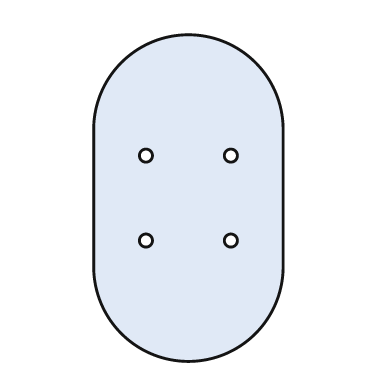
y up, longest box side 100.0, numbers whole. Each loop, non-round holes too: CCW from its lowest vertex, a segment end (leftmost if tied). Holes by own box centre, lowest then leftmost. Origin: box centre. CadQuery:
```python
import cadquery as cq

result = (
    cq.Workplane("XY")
    .moveTo(-29.0, -21.0)
    .threePointArc((0.0, -50.0), (29.0, -21.0))
    .lineTo(29.0, 21.0)
    .threePointArc((0.0, 50.0), (-29.0, 21.0))
    .close()
    .moveTo(-13.0, -13.0)
    .circle(2.0)
    .moveTo(13.0, -13.0)
    .circle(2.0)
    .moveTo(-13.0, 13.0)
    .circle(2.0)
    .moveTo(13.0, 13.0)
    .circle(2.0)
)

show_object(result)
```